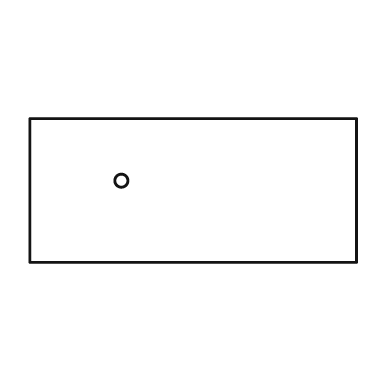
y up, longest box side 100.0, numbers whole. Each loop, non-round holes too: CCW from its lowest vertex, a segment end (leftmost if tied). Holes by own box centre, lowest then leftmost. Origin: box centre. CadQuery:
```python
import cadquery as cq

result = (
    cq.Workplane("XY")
    .moveTo(-50.0, -22.0)
    .lineTo(50.0, -22.0)
    .lineTo(50.0, 22.0)
    .lineTo(-50.0, 22.0)
    .close()
    .moveTo(-22.0, 3.0)
    .circle(2.0)
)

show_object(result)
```